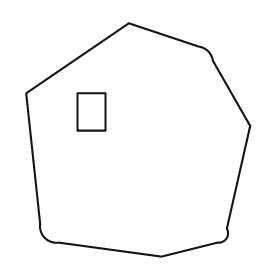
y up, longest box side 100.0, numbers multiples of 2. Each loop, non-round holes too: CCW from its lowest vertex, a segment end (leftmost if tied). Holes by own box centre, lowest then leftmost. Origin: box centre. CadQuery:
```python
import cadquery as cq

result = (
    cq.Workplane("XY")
    .moveTo(10.0, -50.0)
    .lineTo(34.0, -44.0)
    .threePointArc((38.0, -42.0), (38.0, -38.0))
    .lineTo(48.0, 6.0)
    .lineTo(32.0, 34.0)
    .threePointArc((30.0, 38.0), (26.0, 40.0))
    .lineTo(-4.0, 50.0)
    .lineTo(-48.0, 20.0)
    .lineTo(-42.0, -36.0)
    .threePointArc((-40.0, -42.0), (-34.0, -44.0))
    .close()
    .moveTo(-26.0, 4.0)
    .lineTo(-14.0, 4.0)
    .lineTo(-14.0, 20.0)
    .lineTo(-26.0, 20.0)
    .close()
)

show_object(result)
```